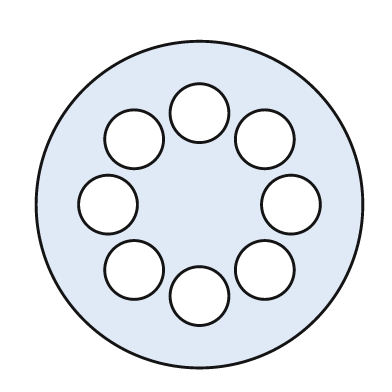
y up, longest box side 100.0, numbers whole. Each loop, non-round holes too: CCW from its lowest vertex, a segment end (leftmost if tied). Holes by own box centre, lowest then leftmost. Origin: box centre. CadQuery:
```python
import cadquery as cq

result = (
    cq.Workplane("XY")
    .moveTo(0.0, 0.0)
    .circle(50.0)
    .moveTo(0.0, -28.0)
    .circle(9.0)
    .moveTo(-20.0, -20.0)
    .circle(9.0)
    .moveTo(20.0, -20.0)
    .circle(9.0)
    .moveTo(-28.0, 0.0)
    .circle(9.0)
    .moveTo(28.0, 0.0)
    .circle(9.0)
    .moveTo(-20.0, 20.0)
    .circle(9.0)
    .moveTo(20.0, 20.0)
    .circle(9.0)
    .moveTo(0.0, 28.0)
    .circle(9.0)
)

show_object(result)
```